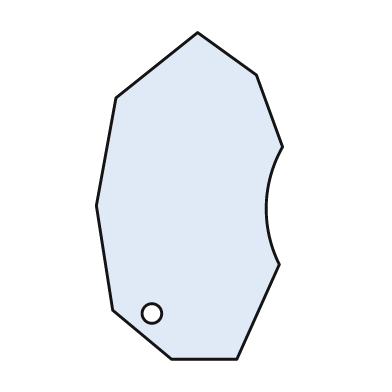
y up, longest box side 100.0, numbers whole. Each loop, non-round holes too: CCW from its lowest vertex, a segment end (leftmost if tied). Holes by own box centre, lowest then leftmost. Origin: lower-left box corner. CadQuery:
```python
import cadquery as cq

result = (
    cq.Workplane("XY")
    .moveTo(23.0, 0.0)
    .lineTo(43.0, 0.0)
    .lineTo(56.0, 29.0)
    .threePointArc((52.0, 47.0), (57.0, 65.0))
    .lineTo(49.0, 87.0)
    .lineTo(31.0, 100.0)
    .lineTo(6.0, 80.0)
    .lineTo(0.0, 47.0)
    .lineTo(5.0, 15.0)
    .close()
    .moveTo(17.0, 14.0)
    .circle(3.0)
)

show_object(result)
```